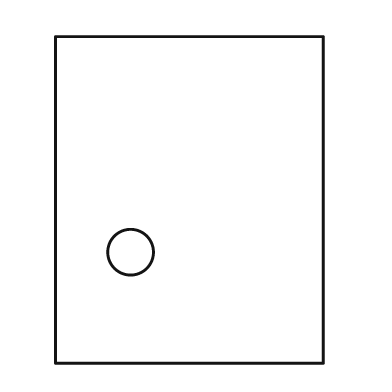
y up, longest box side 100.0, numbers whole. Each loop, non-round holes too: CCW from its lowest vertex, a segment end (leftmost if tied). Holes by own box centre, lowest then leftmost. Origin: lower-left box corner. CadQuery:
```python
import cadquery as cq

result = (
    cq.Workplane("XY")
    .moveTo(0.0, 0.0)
    .lineTo(82.0, 0.0)
    .lineTo(82.0, 100.0)
    .lineTo(0.0, 100.0)
    .close()
    .moveTo(23.0, 34.0)
    .circle(7.0)
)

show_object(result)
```